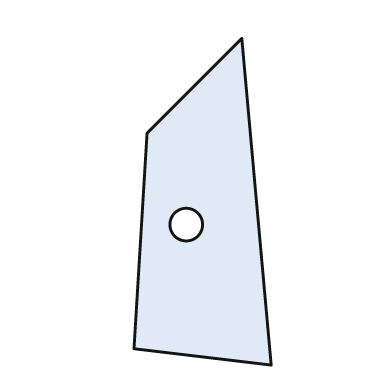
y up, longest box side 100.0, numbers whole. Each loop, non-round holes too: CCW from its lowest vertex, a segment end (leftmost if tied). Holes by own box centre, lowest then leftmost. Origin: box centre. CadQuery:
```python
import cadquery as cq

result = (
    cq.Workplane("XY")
    .moveTo(21.0, -50.0)
    .lineTo(12.0, 50.0)
    .lineTo(-17.0, 21.0)
    .lineTo(-21.0, -45.0)
    .close()
    .moveTo(-5.0, -7.0)
    .circle(5.0)
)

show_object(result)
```